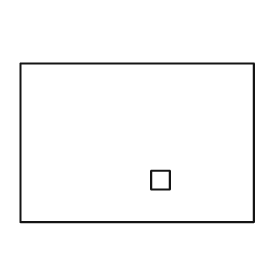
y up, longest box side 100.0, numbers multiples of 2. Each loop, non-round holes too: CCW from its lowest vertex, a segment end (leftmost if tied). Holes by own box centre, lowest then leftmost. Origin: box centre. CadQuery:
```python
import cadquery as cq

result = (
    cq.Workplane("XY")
    .moveTo(-50.0, -34.0)
    .lineTo(50.0, -34.0)
    .lineTo(50.0, 34.0)
    .lineTo(-50.0, 34.0)
    .close()
    .moveTo(6.0, -20.0)
    .lineTo(14.0, -20.0)
    .lineTo(14.0, -12.0)
    .lineTo(6.0, -12.0)
    .close()
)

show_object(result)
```